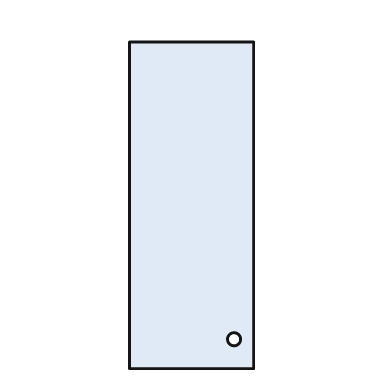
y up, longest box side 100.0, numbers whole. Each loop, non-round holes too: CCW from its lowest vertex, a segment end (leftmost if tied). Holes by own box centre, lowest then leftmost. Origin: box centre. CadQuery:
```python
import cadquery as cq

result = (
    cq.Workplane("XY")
    .moveTo(-19.0, -50.0)
    .lineTo(19.0, -50.0)
    .lineTo(19.0, 50.0)
    .lineTo(-19.0, 50.0)
    .close()
    .moveTo(13.0, -41.0)
    .circle(2.0)
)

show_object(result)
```